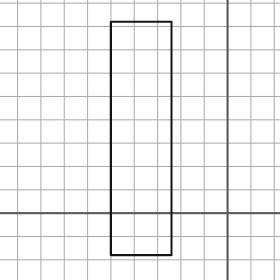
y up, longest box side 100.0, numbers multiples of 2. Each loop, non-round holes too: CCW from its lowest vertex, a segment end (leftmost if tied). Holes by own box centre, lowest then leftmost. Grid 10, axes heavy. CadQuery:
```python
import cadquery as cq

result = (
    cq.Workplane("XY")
    .moveTo(-50.0, -18.0)
    .lineTo(-24.0, -18.0)
    .lineTo(-24.0, 82.0)
    .lineTo(-50.0, 82.0)
    .close()
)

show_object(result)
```